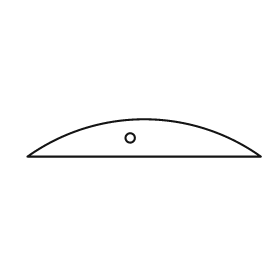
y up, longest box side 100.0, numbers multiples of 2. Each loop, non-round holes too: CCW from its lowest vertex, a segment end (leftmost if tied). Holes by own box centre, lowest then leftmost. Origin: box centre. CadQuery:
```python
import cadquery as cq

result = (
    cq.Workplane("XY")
    .moveTo(-50.0, -8.0)
    .lineTo(50.0, -8.0)
    .threePointArc((0.0, 8.0), (-50.0, -8.0))
    .close()
    .moveTo(-6.0, 0.0)
    .circle(2.0)
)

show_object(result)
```